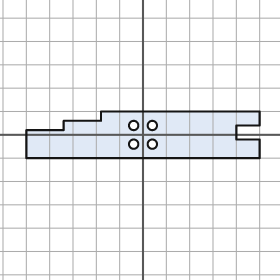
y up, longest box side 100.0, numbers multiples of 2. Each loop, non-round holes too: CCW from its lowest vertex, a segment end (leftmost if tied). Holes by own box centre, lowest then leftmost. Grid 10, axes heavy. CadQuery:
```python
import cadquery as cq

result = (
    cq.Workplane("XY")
    .moveTo(-50.0, -10.0)
    .lineTo(50.0, -10.0)
    .lineTo(50.0, -2.0)
    .lineTo(40.0, -2.0)
    .lineTo(40.0, 4.0)
    .lineTo(50.0, 4.0)
    .lineTo(50.0, 10.0)
    .lineTo(-18.0, 10.0)
    .lineTo(-18.0, 6.0)
    .lineTo(-34.0, 6.0)
    .lineTo(-34.0, 2.0)
    .lineTo(-50.0, 2.0)
    .close()
    .moveTo(-4.0, -4.0)
    .circle(2.0)
    .moveTo(4.0, -4.0)
    .circle(2.0)
    .moveTo(-4.0, 4.0)
    .circle(2.0)
    .moveTo(4.0, 4.0)
    .circle(2.0)
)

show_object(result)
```